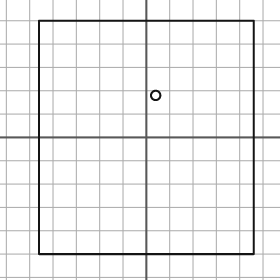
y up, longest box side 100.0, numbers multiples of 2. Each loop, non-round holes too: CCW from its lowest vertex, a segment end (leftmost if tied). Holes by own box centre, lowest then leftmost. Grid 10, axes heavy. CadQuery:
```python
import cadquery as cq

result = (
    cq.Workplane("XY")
    .moveTo(-46.0, -50.0)
    .lineTo(46.0, -50.0)
    .lineTo(46.0, 50.0)
    .lineTo(-46.0, 50.0)
    .close()
    .moveTo(4.0, 18.0)
    .circle(2.0)
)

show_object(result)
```